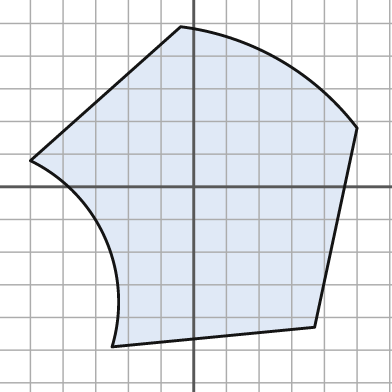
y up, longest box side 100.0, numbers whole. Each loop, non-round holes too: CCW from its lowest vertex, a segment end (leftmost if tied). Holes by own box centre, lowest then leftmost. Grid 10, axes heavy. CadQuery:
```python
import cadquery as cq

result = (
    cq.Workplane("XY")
    .moveTo(-25.0, -49.0)
    .lineTo(37.0, -43.0)
    .lineTo(50.0, 18.0)
    .threePointArc((26.0, 39.0), (-4.0, 49.0))
    .lineTo(-50.0, 8.0)
    .threePointArc((-27.0, -16.0), (-25.0, -49.0))
    .close()
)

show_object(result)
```